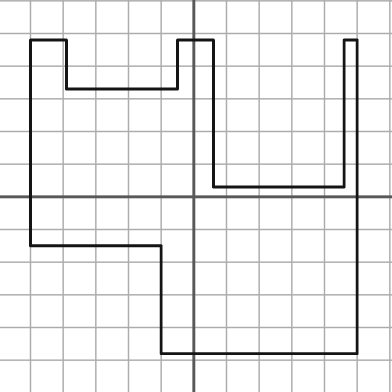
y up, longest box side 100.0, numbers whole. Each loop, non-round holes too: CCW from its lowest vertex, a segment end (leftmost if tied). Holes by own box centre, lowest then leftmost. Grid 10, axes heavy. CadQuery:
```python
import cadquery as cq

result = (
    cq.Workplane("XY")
    .moveTo(-10.0, -48.0)
    .lineTo(50.0, -48.0)
    .lineTo(50.0, 48.0)
    .lineTo(46.0, 48.0)
    .lineTo(46.0, 3.0)
    .lineTo(6.0, 3.0)
    .lineTo(6.0, 48.0)
    .lineTo(-5.0, 48.0)
    .lineTo(-5.0, 33.0)
    .lineTo(-39.0, 33.0)
    .lineTo(-39.0, 48.0)
    .lineTo(-50.0, 48.0)
    .lineTo(-50.0, -15.0)
    .lineTo(-10.0, -15.0)
    .close()
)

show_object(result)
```